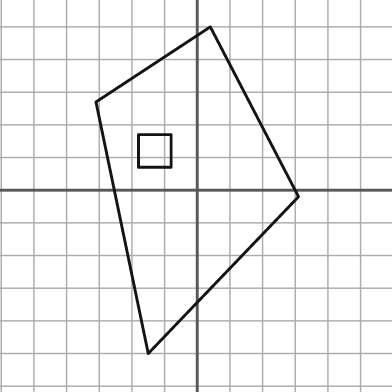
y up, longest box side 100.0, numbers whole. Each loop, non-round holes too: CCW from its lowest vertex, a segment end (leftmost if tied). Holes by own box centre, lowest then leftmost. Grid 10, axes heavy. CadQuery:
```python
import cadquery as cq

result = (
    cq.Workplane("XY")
    .moveTo(-15.0, -50.0)
    .lineTo(31.0, -2.0)
    .lineTo(4.0, 50.0)
    .lineTo(-31.0, 27.0)
    .close()
    .moveTo(-18.0, 7.0)
    .lineTo(-8.0, 7.0)
    .lineTo(-8.0, 17.0)
    .lineTo(-18.0, 17.0)
    .close()
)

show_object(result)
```